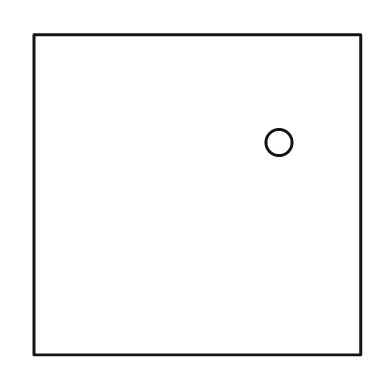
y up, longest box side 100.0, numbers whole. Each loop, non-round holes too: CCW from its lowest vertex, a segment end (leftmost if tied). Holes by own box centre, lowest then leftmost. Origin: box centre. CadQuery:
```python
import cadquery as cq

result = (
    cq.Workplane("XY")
    .moveTo(-50.0, -49.0)
    .lineTo(50.0, -49.0)
    .lineTo(50.0, 49.0)
    .lineTo(-50.0, 49.0)
    .close()
    .moveTo(25.0, 16.0)
    .circle(4.0)
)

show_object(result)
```